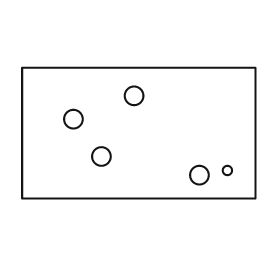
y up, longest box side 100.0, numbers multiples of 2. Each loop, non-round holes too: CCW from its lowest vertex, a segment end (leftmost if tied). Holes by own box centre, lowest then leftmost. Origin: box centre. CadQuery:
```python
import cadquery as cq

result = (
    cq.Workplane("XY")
    .moveTo(-50.0, -28.0)
    .lineTo(50.0, -28.0)
    .lineTo(50.0, 28.0)
    .lineTo(-50.0, 28.0)
    .close()
    .moveTo(26.0, -18.0)
    .circle(4.0)
    .moveTo(38.0, -16.0)
    .circle(2.0)
    .moveTo(-16.0, -10.0)
    .circle(4.0)
    .moveTo(-28.0, 6.0)
    .circle(4.0)
    .moveTo(-2.0, 16.0)
    .circle(4.0)
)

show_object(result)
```